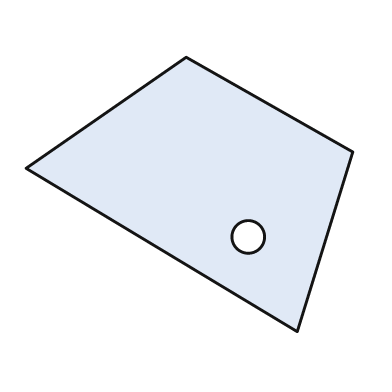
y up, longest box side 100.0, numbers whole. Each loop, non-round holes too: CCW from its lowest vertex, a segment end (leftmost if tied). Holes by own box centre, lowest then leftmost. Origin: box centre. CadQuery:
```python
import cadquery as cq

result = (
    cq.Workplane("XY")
    .moveTo(33.0, -42.0)
    .lineTo(50.0, 13.0)
    .lineTo(-1.0, 42.0)
    .lineTo(-50.0, 8.0)
    .close()
    .moveTo(18.0, -13.0)
    .circle(5.0)
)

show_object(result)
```